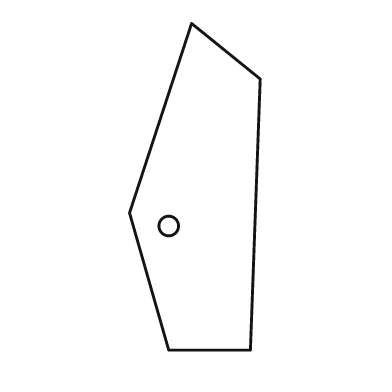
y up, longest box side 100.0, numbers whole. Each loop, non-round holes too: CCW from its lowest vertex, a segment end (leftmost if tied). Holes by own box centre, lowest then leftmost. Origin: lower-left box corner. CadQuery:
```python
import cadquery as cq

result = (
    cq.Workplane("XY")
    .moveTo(12.0, 0.0)
    .lineTo(37.0, 0.0)
    .lineTo(40.0, 83.0)
    .lineTo(19.0, 100.0)
    .lineTo(0.0, 42.0)
    .close()
    .moveTo(12.0, 38.0)
    .circle(3.0)
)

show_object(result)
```